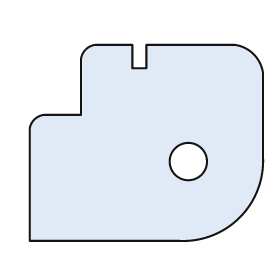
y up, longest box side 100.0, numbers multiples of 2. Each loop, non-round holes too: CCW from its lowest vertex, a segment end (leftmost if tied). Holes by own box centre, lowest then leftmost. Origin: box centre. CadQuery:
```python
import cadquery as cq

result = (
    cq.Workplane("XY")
    .moveTo(-50.0, -42.0)
    .lineTo(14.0, -42.0)
    .threePointArc((40.0, -32.0), (50.0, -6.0))
    .lineTo(50.0, 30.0)
    .threePointArc((46.0, 38.0), (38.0, 42.0))
    .lineTo(0.0, 42.0)
    .lineTo(0.0, 32.0)
    .lineTo(-6.0, 32.0)
    .lineTo(-6.0, 42.0)
    .lineTo(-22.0, 42.0)
    .threePointArc((-26.0, 40.0), (-28.0, 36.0))
    .lineTo(-28.0, 12.0)
    .lineTo(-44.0, 12.0)
    .threePointArc((-48.0, 10.0), (-50.0, 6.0))
    .close()
    .moveTo(18.0, -8.0)
    .circle(8.0)
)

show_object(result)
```